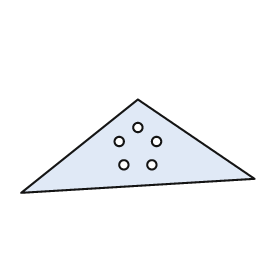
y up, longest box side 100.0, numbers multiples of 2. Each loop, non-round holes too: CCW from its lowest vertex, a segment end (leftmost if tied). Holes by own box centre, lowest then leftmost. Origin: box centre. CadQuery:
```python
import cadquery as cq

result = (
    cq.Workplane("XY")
    .moveTo(-50.0, -20.0)
    .lineTo(50.0, -14.0)
    .lineTo(0.0, 20.0)
    .close()
    .moveTo(-6.0, -8.0)
    .circle(2.0)
    .moveTo(6.0, -8.0)
    .circle(2.0)
    .moveTo(-8.0, 2.0)
    .circle(2.0)
    .moveTo(8.0, 2.0)
    .circle(2.0)
    .moveTo(0.0, 8.0)
    .circle(2.0)
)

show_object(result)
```